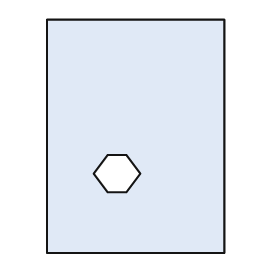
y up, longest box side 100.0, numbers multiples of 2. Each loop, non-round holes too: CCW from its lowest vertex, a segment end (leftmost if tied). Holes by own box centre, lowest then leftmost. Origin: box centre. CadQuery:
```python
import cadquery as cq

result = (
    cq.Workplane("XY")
    .moveTo(-38.0, -50.0)
    .lineTo(38.0, -50.0)
    .lineTo(38.0, 50.0)
    .lineTo(-38.0, 50.0)
    .close()
    .moveTo(-12.0, -24.0)
    .lineTo(-4.0, -24.0)
    .lineTo(2.0, -16.0)
    .lineTo(-4.0, -8.0)
    .lineTo(-12.0, -8.0)
    .lineTo(-18.0, -16.0)
    .close()
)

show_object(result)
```